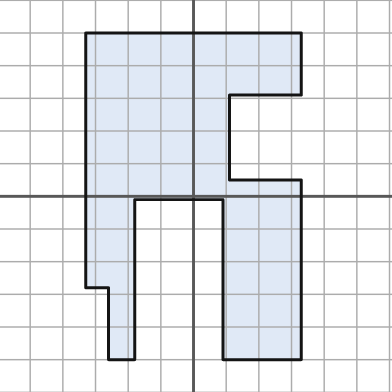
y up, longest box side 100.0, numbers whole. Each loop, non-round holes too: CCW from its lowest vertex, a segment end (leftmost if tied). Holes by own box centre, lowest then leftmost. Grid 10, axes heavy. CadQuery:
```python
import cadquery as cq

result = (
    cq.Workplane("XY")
    .moveTo(-26.0, -50.0)
    .lineTo(-18.0, -50.0)
    .lineTo(-18.0, -1.0)
    .lineTo(9.0, -1.0)
    .lineTo(9.0, -50.0)
    .lineTo(33.0, -50.0)
    .lineTo(33.0, 5.0)
    .lineTo(11.0, 5.0)
    .lineTo(11.0, 31.0)
    .lineTo(33.0, 31.0)
    .lineTo(33.0, 50.0)
    .lineTo(-33.0, 50.0)
    .lineTo(-33.0, -28.0)
    .lineTo(-26.0, -28.0)
    .close()
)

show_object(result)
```